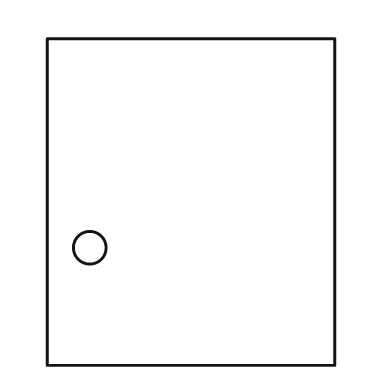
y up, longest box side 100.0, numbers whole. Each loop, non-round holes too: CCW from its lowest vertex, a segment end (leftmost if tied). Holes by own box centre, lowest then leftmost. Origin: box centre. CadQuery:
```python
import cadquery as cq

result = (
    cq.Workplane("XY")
    .moveTo(-44.0, -50.0)
    .lineTo(44.0, -50.0)
    .lineTo(44.0, 50.0)
    .lineTo(-44.0, 50.0)
    .close()
    .moveTo(-31.0, -14.0)
    .circle(5.0)
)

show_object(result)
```